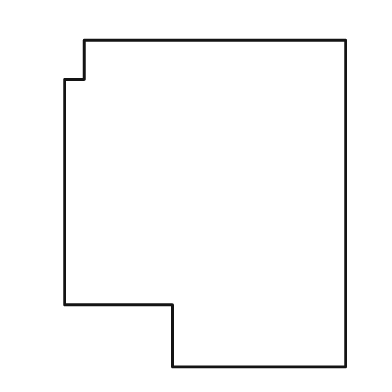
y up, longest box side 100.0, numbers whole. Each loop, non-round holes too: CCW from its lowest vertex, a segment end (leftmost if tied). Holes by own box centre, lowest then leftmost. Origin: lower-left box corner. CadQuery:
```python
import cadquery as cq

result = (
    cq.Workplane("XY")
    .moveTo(33.0, 0.0)
    .lineTo(86.0, 0.0)
    .lineTo(86.0, 100.0)
    .lineTo(6.0, 100.0)
    .lineTo(6.0, 88.0)
    .lineTo(0.0, 88.0)
    .lineTo(0.0, 19.0)
    .lineTo(33.0, 19.0)
    .close()
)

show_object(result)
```